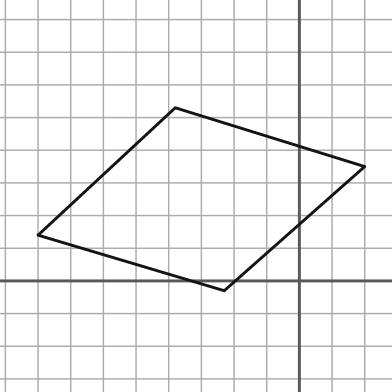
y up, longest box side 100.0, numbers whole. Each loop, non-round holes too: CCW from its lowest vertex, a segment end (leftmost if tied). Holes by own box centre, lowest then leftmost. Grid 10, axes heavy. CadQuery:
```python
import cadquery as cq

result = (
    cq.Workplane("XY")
    .moveTo(-23.0, -3.0)
    .lineTo(20.0, 35.0)
    .lineTo(-38.0, 53.0)
    .lineTo(-80.0, 14.0)
    .close()
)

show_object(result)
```